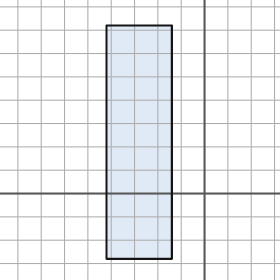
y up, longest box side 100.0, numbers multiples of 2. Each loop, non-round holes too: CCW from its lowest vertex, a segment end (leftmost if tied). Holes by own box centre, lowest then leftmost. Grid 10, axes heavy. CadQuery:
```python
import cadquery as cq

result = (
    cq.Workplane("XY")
    .moveTo(-42.0, -28.0)
    .lineTo(-14.0, -28.0)
    .lineTo(-14.0, 72.0)
    .lineTo(-42.0, 72.0)
    .close()
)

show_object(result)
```